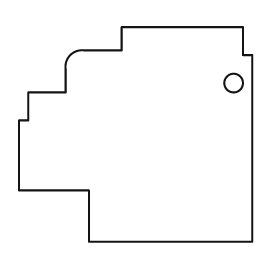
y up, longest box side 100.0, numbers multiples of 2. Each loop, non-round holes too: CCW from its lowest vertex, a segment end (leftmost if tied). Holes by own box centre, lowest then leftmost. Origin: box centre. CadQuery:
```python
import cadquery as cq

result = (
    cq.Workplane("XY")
    .moveTo(-20.0, -46.0)
    .lineTo(50.0, -46.0)
    .lineTo(50.0, 34.0)
    .lineTo(46.0, 34.0)
    .lineTo(46.0, 46.0)
    .lineTo(-6.0, 46.0)
    .lineTo(-6.0, 36.0)
    .lineTo(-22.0, 36.0)
    .threePointArc((-28.0, 34.0), (-30.0, 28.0))
    .lineTo(-30.0, 18.0)
    .lineTo(-46.0, 18.0)
    .lineTo(-46.0, 6.0)
    .lineTo(-50.0, 6.0)
    .lineTo(-50.0, -24.0)
    .lineTo(-20.0, -24.0)
    .close()
    .moveTo(42.0, 22.0)
    .circle(4.0)
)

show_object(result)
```